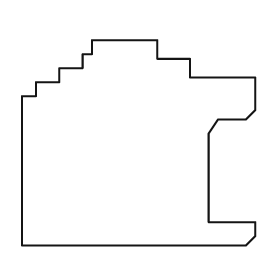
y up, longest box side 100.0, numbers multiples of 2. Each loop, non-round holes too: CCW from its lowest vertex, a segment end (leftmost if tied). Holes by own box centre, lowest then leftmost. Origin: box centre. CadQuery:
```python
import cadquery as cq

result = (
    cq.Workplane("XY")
    .moveTo(-50.0, -44.0)
    .lineTo(46.0, -44.0)
    .lineTo(50.0, -40.0)
    .lineTo(50.0, -34.0)
    .lineTo(30.0, -34.0)
    .lineTo(30.0, 4.0)
    .lineTo(34.0, 10.0)
    .lineTo(46.0, 10.0)
    .lineTo(50.0, 14.0)
    .lineTo(50.0, 28.0)
    .lineTo(22.0, 28.0)
    .lineTo(22.0, 36.0)
    .lineTo(8.0, 36.0)
    .lineTo(8.0, 44.0)
    .lineTo(-20.0, 44.0)
    .lineTo(-20.0, 38.0)
    .lineTo(-24.0, 38.0)
    .lineTo(-24.0, 32.0)
    .lineTo(-34.0, 32.0)
    .lineTo(-34.0, 26.0)
    .lineTo(-44.0, 26.0)
    .lineTo(-44.0, 20.0)
    .lineTo(-50.0, 20.0)
    .close()
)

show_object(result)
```